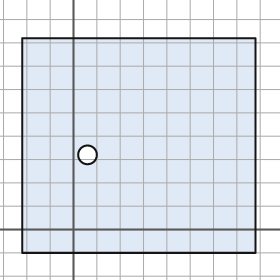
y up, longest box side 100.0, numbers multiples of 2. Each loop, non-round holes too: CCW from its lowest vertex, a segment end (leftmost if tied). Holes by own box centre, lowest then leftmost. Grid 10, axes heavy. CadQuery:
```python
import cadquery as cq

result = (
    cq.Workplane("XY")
    .moveTo(-22.0, -10.0)
    .lineTo(78.0, -10.0)
    .lineTo(78.0, 82.0)
    .lineTo(-22.0, 82.0)
    .close()
    .moveTo(6.0, 32.0)
    .circle(4.0)
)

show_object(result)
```